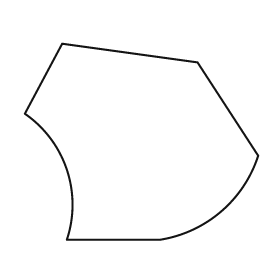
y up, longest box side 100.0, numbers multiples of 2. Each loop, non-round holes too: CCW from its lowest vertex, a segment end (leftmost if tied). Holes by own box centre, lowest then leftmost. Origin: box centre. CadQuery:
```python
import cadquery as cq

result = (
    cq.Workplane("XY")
    .moveTo(-32.0, -42.0)
    .lineTo(8.0, -42.0)
    .threePointArc((34.0, -30.0), (50.0, -6.0))
    .lineTo(24.0, 34.0)
    .lineTo(-34.0, 42.0)
    .lineTo(-50.0, 12.0)
    .threePointArc((-32.0, -12.0), (-32.0, -42.0))
    .close()
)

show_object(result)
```